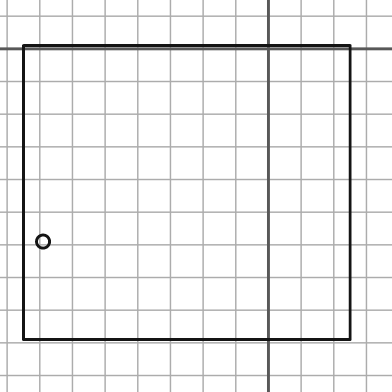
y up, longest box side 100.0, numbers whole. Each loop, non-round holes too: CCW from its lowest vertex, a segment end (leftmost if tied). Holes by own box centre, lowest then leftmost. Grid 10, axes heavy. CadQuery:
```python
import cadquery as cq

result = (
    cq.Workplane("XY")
    .moveTo(-75.0, -89.0)
    .lineTo(25.0, -89.0)
    .lineTo(25.0, 1.0)
    .lineTo(-75.0, 1.0)
    .close()
    .moveTo(-69.0, -59.0)
    .circle(2.0)
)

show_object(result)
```